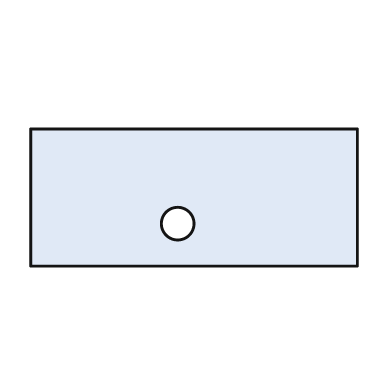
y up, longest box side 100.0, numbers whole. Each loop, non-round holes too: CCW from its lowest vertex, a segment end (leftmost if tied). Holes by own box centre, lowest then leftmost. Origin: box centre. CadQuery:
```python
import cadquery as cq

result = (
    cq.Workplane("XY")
    .moveTo(-50.0, -21.0)
    .lineTo(50.0, -21.0)
    .lineTo(50.0, 21.0)
    .lineTo(-50.0, 21.0)
    .close()
    .moveTo(-5.0, -8.0)
    .circle(5.0)
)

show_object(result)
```